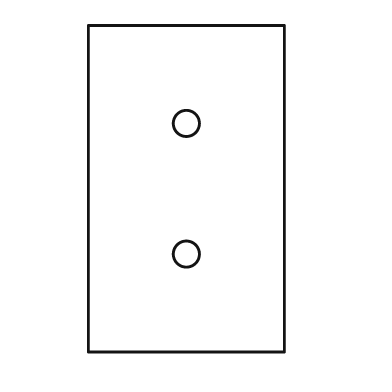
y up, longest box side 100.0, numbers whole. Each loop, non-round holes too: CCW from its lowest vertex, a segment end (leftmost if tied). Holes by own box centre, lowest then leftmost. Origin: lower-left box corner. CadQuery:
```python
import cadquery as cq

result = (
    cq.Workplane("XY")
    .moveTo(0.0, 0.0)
    .lineTo(60.0, 0.0)
    .lineTo(60.0, 100.0)
    .lineTo(0.0, 100.0)
    .close()
    .moveTo(30.0, 30.0)
    .circle(4.0)
    .moveTo(30.0, 70.0)
    .circle(4.0)
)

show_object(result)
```